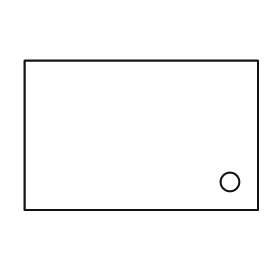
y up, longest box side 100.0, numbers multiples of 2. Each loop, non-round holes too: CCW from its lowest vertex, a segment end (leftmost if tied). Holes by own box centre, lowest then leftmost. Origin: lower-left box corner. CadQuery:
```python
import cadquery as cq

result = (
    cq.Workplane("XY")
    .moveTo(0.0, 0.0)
    .lineTo(100.0, 0.0)
    .lineTo(100.0, 64.0)
    .lineTo(0.0, 64.0)
    .close()
    .moveTo(88.0, 12.0)
    .circle(4.0)
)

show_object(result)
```